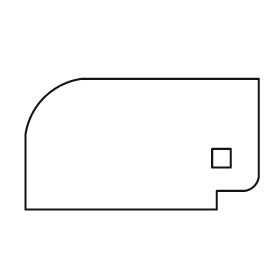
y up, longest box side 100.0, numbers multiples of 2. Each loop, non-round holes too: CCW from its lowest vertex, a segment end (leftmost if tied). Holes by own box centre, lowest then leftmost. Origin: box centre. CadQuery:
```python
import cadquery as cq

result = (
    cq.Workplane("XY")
    .moveTo(-50.0, -28.0)
    .lineTo(32.0, -28.0)
    .lineTo(32.0, -20.0)
    .lineTo(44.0, -20.0)
    .threePointArc((48.0, -18.0), (50.0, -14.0))
    .lineTo(50.0, 28.0)
    .lineTo(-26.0, 28.0)
    .threePointArc((-42.0, 20.0), (-50.0, 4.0))
    .close()
    .moveTo(30.0, -10.0)
    .lineTo(38.0, -10.0)
    .lineTo(38.0, -2.0)
    .lineTo(30.0, -2.0)
    .close()
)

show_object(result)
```